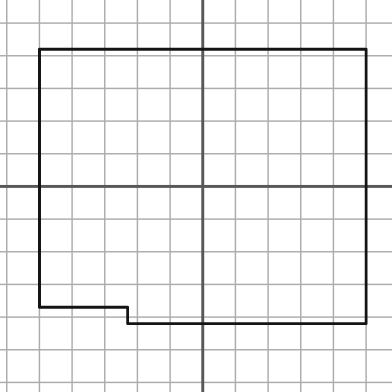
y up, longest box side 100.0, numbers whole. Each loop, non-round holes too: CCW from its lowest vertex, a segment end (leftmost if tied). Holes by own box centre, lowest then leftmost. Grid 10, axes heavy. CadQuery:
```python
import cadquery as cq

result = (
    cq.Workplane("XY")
    .moveTo(-23.0, -42.0)
    .lineTo(50.0, -42.0)
    .lineTo(50.0, 42.0)
    .lineTo(-50.0, 42.0)
    .lineTo(-50.0, -37.0)
    .lineTo(-23.0, -37.0)
    .close()
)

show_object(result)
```